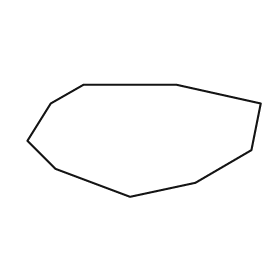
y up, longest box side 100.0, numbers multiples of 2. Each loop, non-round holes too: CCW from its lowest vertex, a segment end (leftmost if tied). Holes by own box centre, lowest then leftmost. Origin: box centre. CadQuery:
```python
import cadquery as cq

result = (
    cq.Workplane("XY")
    .moveTo(-6.0, -24.0)
    .lineTo(22.0, -18.0)
    .lineTo(46.0, -4.0)
    .lineTo(50.0, 16.0)
    .lineTo(14.0, 24.0)
    .lineTo(-26.0, 24.0)
    .lineTo(-40.0, 16.0)
    .lineTo(-50.0, 0.0)
    .lineTo(-38.0, -12.0)
    .close()
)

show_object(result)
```